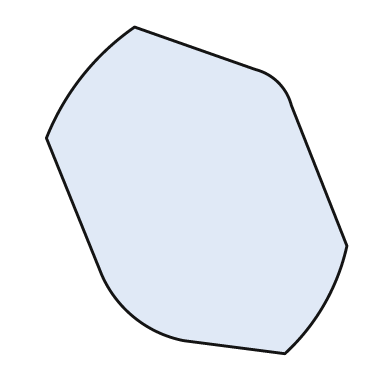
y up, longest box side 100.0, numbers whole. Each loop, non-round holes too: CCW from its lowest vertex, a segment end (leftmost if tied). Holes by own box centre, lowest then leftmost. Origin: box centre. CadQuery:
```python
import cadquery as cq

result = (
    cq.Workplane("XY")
    .moveTo(27.0, -50.0)
    .threePointArc((39.0, -35.0), (46.0, -17.0))
    .lineTo(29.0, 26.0)
    .threePointArc((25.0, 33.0), (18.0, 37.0))
    .lineTo(-19.0, 50.0)
    .threePointArc((-35.0, 35.0), (-46.0, 16.0))
    .lineTo(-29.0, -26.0)
    .threePointArc((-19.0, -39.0), (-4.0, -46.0))
    .close()
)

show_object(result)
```